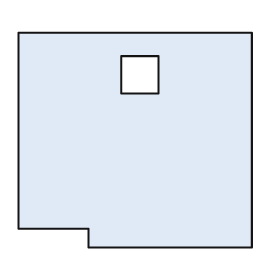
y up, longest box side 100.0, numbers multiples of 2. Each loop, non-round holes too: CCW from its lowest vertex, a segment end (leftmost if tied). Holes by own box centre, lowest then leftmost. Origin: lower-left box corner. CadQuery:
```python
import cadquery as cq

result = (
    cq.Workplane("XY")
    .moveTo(30.0, 0.0)
    .lineTo(100.0, 0.0)
    .lineTo(100.0, 92.0)
    .lineTo(0.0, 92.0)
    .lineTo(0.0, 8.0)
    .lineTo(30.0, 8.0)
    .close()
    .moveTo(44.0, 66.0)
    .lineTo(60.0, 66.0)
    .lineTo(60.0, 82.0)
    .lineTo(44.0, 82.0)
    .close()
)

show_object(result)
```